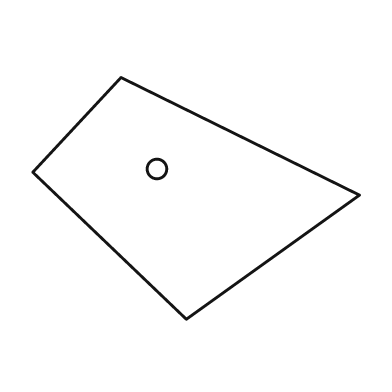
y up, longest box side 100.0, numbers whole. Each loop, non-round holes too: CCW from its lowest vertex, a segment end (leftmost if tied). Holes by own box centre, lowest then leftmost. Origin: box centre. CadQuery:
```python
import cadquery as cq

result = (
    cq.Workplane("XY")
    .moveTo(-3.0, -37.0)
    .lineTo(50.0, 1.0)
    .lineTo(-23.0, 37.0)
    .lineTo(-50.0, 8.0)
    .close()
    .moveTo(-12.0, 9.0)
    .circle(3.0)
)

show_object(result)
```